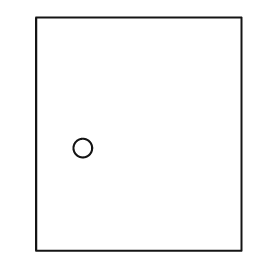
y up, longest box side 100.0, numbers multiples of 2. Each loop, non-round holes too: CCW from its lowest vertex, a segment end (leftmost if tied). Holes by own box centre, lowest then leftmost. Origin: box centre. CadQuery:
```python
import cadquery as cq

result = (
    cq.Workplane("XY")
    .moveTo(-44.0, -50.0)
    .lineTo(44.0, -50.0)
    .lineTo(44.0, 50.0)
    .lineTo(-44.0, 50.0)
    .close()
    .moveTo(-24.0, -6.0)
    .circle(4.0)
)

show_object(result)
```